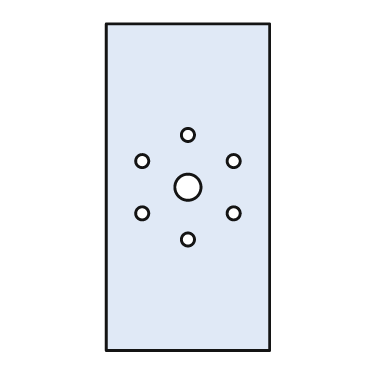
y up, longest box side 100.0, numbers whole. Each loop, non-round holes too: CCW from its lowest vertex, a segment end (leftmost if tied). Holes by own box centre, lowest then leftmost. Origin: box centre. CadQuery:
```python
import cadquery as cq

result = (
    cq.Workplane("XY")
    .moveTo(-25.0, -50.0)
    .lineTo(25.0, -50.0)
    .lineTo(25.0, 50.0)
    .lineTo(-25.0, 50.0)
    .close()
    .moveTo(0.0, -16.0)
    .circle(2.0)
    .moveTo(-14.0, -8.0)
    .circle(2.0)
    .moveTo(14.0, -8.0)
    .circle(2.0)
    .moveTo(0.0, 0.0)
    .circle(4.0)
    .moveTo(-14.0, 8.0)
    .circle(2.0)
    .moveTo(14.0, 8.0)
    .circle(2.0)
    .moveTo(0.0, 16.0)
    .circle(2.0)
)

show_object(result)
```